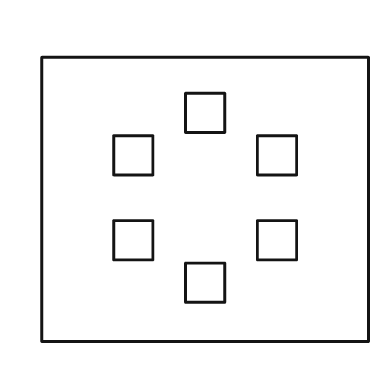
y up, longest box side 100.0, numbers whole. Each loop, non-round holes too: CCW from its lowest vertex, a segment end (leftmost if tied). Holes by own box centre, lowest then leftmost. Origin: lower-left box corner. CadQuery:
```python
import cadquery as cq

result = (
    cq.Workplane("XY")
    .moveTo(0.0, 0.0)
    .lineTo(100.0, 0.0)
    .lineTo(100.0, 87.0)
    .lineTo(0.0, 87.0)
    .close()
    .moveTo(44.0, 12.0)
    .lineTo(56.0, 12.0)
    .lineTo(56.0, 24.0)
    .lineTo(44.0, 24.0)
    .close()
    .moveTo(22.0, 25.0)
    .lineTo(34.0, 25.0)
    .lineTo(34.0, 37.0)
    .lineTo(22.0, 37.0)
    .close()
    .moveTo(66.0, 25.0)
    .lineTo(78.0, 25.0)
    .lineTo(78.0, 37.0)
    .lineTo(66.0, 37.0)
    .close()
    .moveTo(22.0, 51.0)
    .lineTo(34.0, 51.0)
    .lineTo(34.0, 63.0)
    .lineTo(22.0, 63.0)
    .close()
    .moveTo(66.0, 51.0)
    .lineTo(78.0, 51.0)
    .lineTo(78.0, 63.0)
    .lineTo(66.0, 63.0)
    .close()
    .moveTo(44.0, 64.0)
    .lineTo(56.0, 64.0)
    .lineTo(56.0, 76.0)
    .lineTo(44.0, 76.0)
    .close()
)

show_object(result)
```